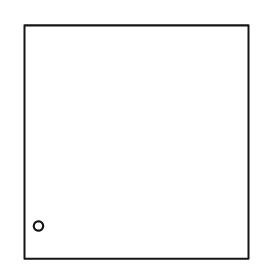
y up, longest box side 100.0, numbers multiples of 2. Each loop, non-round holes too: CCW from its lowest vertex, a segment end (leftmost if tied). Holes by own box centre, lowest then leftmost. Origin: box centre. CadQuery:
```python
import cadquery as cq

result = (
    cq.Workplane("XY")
    .moveTo(-48.0, -50.0)
    .lineTo(48.0, -50.0)
    .lineTo(48.0, 50.0)
    .lineTo(-48.0, 50.0)
    .close()
    .moveTo(-42.0, -36.0)
    .circle(2.0)
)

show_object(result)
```